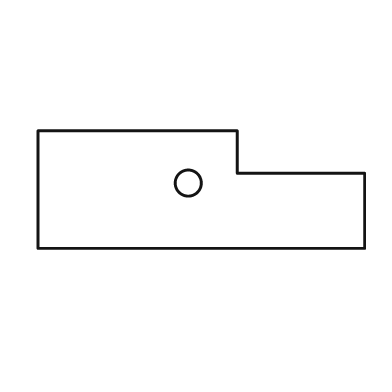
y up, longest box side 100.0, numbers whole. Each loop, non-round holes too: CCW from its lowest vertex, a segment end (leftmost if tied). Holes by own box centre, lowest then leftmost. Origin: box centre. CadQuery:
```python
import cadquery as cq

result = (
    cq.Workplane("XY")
    .moveTo(-50.0, -18.0)
    .lineTo(50.0, -18.0)
    .lineTo(50.0, 5.0)
    .lineTo(11.0, 5.0)
    .lineTo(11.0, 18.0)
    .lineTo(-50.0, 18.0)
    .close()
    .moveTo(-4.0, 2.0)
    .circle(4.0)
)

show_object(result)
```